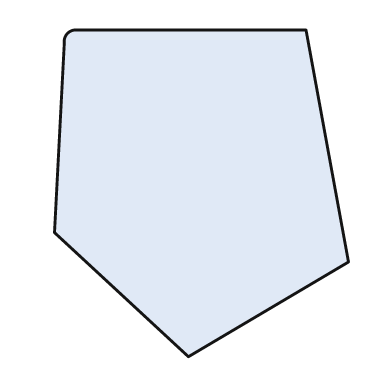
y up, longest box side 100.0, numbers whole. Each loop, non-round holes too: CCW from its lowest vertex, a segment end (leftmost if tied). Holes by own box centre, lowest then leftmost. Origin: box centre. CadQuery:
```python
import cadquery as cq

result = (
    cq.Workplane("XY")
    .moveTo(-4.0, -50.0)
    .lineTo(45.0, -21.0)
    .lineTo(32.0, 50.0)
    .lineTo(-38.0, 50.0)
    .threePointArc((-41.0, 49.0), (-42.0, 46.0))
    .lineTo(-45.0, -12.0)
    .close()
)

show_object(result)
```